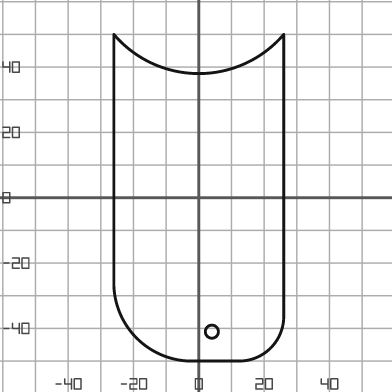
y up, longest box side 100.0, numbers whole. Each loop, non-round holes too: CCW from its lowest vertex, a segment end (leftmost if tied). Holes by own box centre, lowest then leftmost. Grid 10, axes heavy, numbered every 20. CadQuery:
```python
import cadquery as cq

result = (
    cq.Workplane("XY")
    .moveTo(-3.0, -50.0)
    .lineTo(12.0, -50.0)
    .threePointArc((22.0, -46.0), (26.0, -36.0))
    .lineTo(26.0, 50.0)
    .threePointArc((0.0, 38.0), (-26.0, 50.0))
    .lineTo(-26.0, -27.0)
    .threePointArc((-19.0, -43.0), (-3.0, -50.0))
    .close()
    .moveTo(4.0, -41.0)
    .circle(2.0)
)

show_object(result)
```